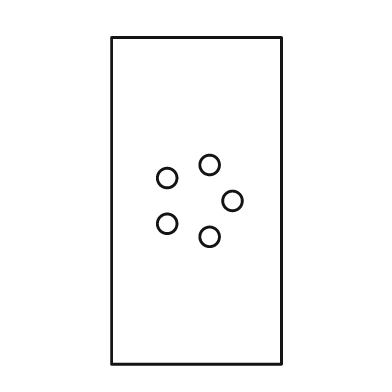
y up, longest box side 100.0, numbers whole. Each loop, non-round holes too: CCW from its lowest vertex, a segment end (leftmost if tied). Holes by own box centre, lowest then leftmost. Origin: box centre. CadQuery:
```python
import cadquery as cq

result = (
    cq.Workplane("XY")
    .moveTo(-26.0, -50.0)
    .lineTo(26.0, -50.0)
    .lineTo(26.0, 50.0)
    .lineTo(-26.0, 50.0)
    .close()
    .moveTo(4.0, -11.0)
    .circle(3.0)
    .moveTo(-9.0, -7.0)
    .circle(3.0)
    .moveTo(11.0, 0.0)
    .circle(3.0)
    .moveTo(-9.0, 7.0)
    .circle(3.0)
    .moveTo(4.0, 11.0)
    .circle(3.0)
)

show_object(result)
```